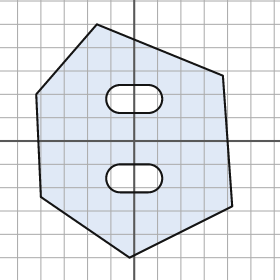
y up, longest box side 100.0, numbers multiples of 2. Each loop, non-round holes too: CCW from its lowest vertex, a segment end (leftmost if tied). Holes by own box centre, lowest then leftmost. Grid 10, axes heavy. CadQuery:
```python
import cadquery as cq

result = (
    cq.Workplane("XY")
    .moveTo(-2.0, -50.0)
    .lineTo(42.0, -28.0)
    .lineTo(38.0, 28.0)
    .lineTo(-16.0, 50.0)
    .lineTo(-42.0, 20.0)
    .lineTo(-40.0, -24.0)
    .close()
    .moveTo(-6.0, -22.0)
    .lineTo(6.0, -22.0)
    .threePointArc((12.0, -16.0), (6.0, -10.0))
    .lineTo(-6.0, -10.0)
    .threePointArc((-12.0, -16.0), (-6.0, -22.0))
    .close()
    .moveTo(-6.0, 12.0)
    .lineTo(6.0, 12.0)
    .threePointArc((12.0, 18.0), (6.0, 24.0))
    .lineTo(-6.0, 24.0)
    .threePointArc((-12.0, 18.0), (-6.0, 12.0))
    .close()
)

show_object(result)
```